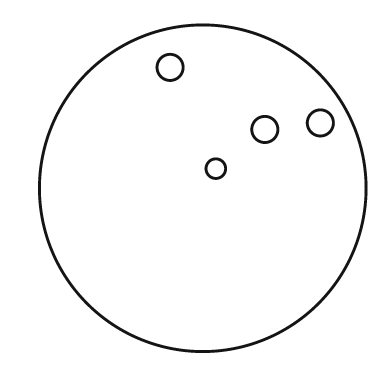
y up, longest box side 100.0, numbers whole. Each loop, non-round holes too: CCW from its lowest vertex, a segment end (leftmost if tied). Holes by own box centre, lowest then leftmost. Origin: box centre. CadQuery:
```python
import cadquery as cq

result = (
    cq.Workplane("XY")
    .moveTo(0.0, 0.0)
    .circle(50.0)
    .moveTo(4.0, 6.0)
    .circle(3.0)
    .moveTo(19.0, 18.0)
    .circle(4.0)
    .moveTo(36.0, 20.0)
    .circle(4.0)
    .moveTo(-10.0, 37.0)
    .circle(4.0)
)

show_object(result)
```